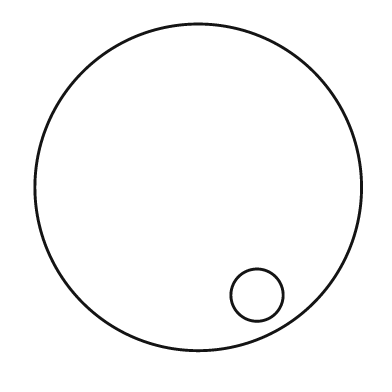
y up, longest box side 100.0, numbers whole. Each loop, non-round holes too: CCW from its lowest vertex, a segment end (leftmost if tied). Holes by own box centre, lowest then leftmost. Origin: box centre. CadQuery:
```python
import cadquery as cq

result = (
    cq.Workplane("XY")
    .moveTo(0.0, 0.0)
    .circle(50.0)
    .moveTo(18.0, -33.0)
    .circle(8.0)
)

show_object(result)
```